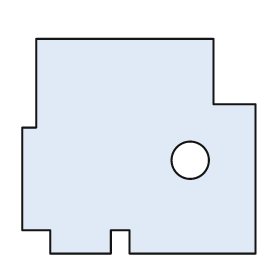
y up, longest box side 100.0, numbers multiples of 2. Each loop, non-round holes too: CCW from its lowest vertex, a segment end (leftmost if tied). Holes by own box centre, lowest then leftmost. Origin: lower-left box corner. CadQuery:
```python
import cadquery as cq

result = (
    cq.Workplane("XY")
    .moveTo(12.0, 0.0)
    .lineTo(38.0, 0.0)
    .lineTo(38.0, 10.0)
    .lineTo(46.0, 10.0)
    .lineTo(46.0, 0.0)
    .lineTo(100.0, 0.0)
    .lineTo(100.0, 64.0)
    .lineTo(82.0, 64.0)
    .lineTo(82.0, 92.0)
    .lineTo(6.0, 92.0)
    .lineTo(6.0, 54.0)
    .lineTo(0.0, 54.0)
    .lineTo(0.0, 10.0)
    .lineTo(12.0, 10.0)
    .close()
    .moveTo(72.0, 40.0)
    .circle(8.0)
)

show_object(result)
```